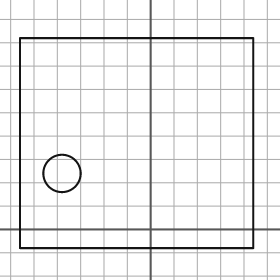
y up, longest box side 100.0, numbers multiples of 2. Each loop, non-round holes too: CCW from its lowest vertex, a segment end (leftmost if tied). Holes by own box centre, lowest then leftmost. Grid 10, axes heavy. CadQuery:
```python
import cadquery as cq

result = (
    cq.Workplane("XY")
    .moveTo(-56.0, -8.0)
    .lineTo(44.0, -8.0)
    .lineTo(44.0, 82.0)
    .lineTo(-56.0, 82.0)
    .close()
    .moveTo(-38.0, 24.0)
    .circle(8.0)
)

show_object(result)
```